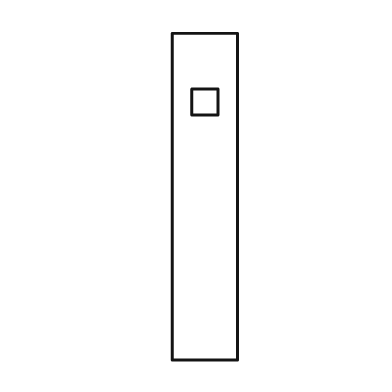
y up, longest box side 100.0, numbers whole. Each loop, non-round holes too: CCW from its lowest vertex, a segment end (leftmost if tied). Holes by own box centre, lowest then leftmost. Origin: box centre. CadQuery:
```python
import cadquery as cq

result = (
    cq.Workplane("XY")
    .moveTo(-10.0, -50.0)
    .lineTo(10.0, -50.0)
    .lineTo(10.0, 50.0)
    .lineTo(-10.0, 50.0)
    .close()
    .moveTo(-4.0, 25.0)
    .lineTo(4.0, 25.0)
    .lineTo(4.0, 33.0)
    .lineTo(-4.0, 33.0)
    .close()
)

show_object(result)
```